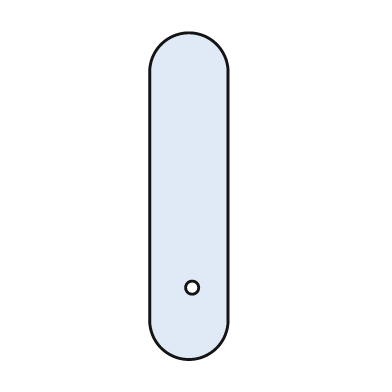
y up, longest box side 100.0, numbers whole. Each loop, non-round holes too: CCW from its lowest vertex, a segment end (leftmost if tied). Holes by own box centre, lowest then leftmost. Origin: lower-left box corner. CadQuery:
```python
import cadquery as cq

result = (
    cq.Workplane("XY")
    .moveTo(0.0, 12.0)
    .threePointArc((12.0, 0.0), (24.0, 12.0))
    .lineTo(24.0, 88.0)
    .threePointArc((12.0, 100.0), (0.0, 88.0))
    .close()
    .moveTo(13.0, 22.0)
    .circle(2.0)
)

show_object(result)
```